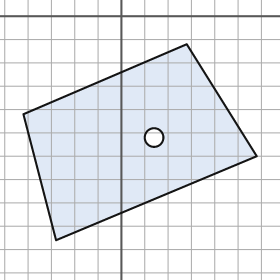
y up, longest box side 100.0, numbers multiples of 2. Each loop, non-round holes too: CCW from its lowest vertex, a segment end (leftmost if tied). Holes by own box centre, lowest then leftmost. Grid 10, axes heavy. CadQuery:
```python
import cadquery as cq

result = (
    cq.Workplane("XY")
    .moveTo(-28.0, -96.0)
    .lineTo(58.0, -60.0)
    .lineTo(28.0, -12.0)
    .lineTo(-42.0, -42.0)
    .close()
    .moveTo(14.0, -52.0)
    .circle(4.0)
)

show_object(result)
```